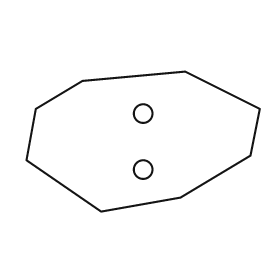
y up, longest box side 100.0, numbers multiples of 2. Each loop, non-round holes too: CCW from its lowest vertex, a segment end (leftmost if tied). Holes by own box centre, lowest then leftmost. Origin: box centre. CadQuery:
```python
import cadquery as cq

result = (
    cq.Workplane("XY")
    .moveTo(-18.0, -30.0)
    .lineTo(16.0, -24.0)
    .lineTo(46.0, -6.0)
    .lineTo(50.0, 14.0)
    .lineTo(18.0, 30.0)
    .lineTo(-26.0, 26.0)
    .lineTo(-46.0, 14.0)
    .lineTo(-50.0, -8.0)
    .close()
    .moveTo(0.0, -12.0)
    .circle(4.0)
    .moveTo(0.0, 12.0)
    .circle(4.0)
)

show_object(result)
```